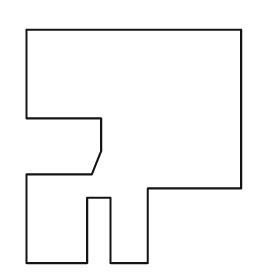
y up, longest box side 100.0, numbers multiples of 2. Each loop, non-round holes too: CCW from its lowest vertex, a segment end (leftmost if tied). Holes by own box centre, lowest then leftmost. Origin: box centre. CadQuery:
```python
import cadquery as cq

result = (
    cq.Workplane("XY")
    .moveTo(-46.0, -50.0)
    .lineTo(-20.0, -50.0)
    .lineTo(-20.0, -22.0)
    .lineTo(-10.0, -22.0)
    .lineTo(-10.0, -50.0)
    .lineTo(6.0, -50.0)
    .lineTo(6.0, -18.0)
    .lineTo(46.0, -18.0)
    .lineTo(46.0, 50.0)
    .lineTo(-46.0, 50.0)
    .lineTo(-46.0, 12.0)
    .lineTo(-14.0, 12.0)
    .lineTo(-14.0, -2.0)
    .lineTo(-18.0, -12.0)
    .lineTo(-46.0, -12.0)
    .close()
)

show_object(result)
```